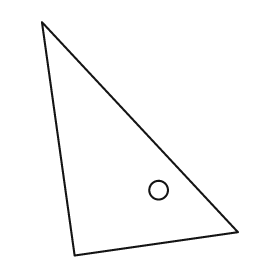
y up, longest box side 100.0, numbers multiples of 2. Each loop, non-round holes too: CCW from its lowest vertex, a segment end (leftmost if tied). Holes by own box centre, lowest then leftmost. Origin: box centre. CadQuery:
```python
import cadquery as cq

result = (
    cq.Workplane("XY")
    .moveTo(-28.0, -50.0)
    .lineTo(42.0, -40.0)
    .lineTo(-42.0, 50.0)
    .close()
    .moveTo(8.0, -22.0)
    .circle(4.0)
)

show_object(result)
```